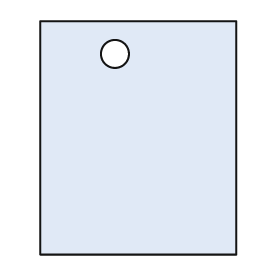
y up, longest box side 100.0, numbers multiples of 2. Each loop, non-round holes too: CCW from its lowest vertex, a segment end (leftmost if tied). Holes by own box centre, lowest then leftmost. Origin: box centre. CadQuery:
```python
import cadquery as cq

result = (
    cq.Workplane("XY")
    .moveTo(-42.0, -50.0)
    .lineTo(42.0, -50.0)
    .lineTo(42.0, 50.0)
    .lineTo(-42.0, 50.0)
    .close()
    .moveTo(-10.0, 36.0)
    .circle(6.0)
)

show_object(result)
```